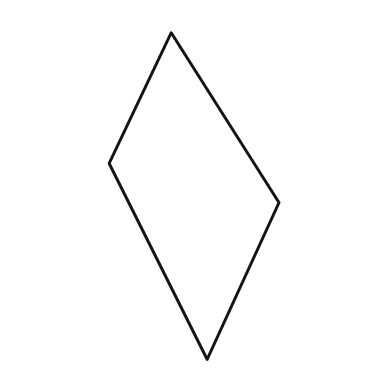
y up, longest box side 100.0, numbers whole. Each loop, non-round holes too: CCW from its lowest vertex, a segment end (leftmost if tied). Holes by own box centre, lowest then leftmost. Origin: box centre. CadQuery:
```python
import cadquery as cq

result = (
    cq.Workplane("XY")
    .moveTo(4.0, -50.0)
    .lineTo(26.0, -2.0)
    .lineTo(-7.0, 50.0)
    .lineTo(-26.0, 10.0)
    .close()
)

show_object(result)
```